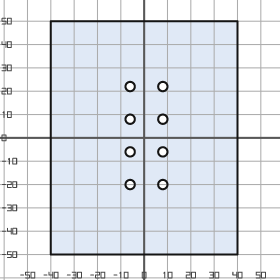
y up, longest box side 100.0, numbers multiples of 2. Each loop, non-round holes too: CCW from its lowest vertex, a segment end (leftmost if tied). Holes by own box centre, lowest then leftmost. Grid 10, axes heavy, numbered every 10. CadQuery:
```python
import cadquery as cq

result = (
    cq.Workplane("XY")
    .moveTo(-40.0, -50.0)
    .lineTo(40.0, -50.0)
    .lineTo(40.0, 50.0)
    .lineTo(-40.0, 50.0)
    .close()
    .moveTo(-6.0, -20.0)
    .circle(2.0)
    .moveTo(8.0, -20.0)
    .circle(2.0)
    .moveTo(-6.0, -6.0)
    .circle(2.0)
    .moveTo(8.0, -6.0)
    .circle(2.0)
    .moveTo(-6.0, 8.0)
    .circle(2.0)
    .moveTo(8.0, 8.0)
    .circle(2.0)
    .moveTo(-6.0, 22.0)
    .circle(2.0)
    .moveTo(8.0, 22.0)
    .circle(2.0)
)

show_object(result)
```